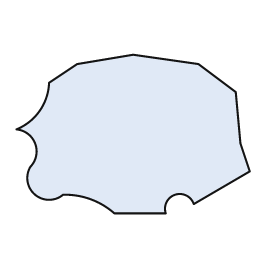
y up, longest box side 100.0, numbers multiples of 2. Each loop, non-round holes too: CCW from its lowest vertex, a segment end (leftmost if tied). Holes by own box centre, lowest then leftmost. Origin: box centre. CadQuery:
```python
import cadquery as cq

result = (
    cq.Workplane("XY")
    .moveTo(-8.0, -34.0)
    .lineTo(14.0, -34.0)
    .threePointArc((18.0, -26.0), (26.0, -30.0))
    .lineTo(50.0, -16.0)
    .lineTo(46.0, -4.0)
    .lineTo(44.0, 18.0)
    .lineTo(28.0, 30.0)
    .lineTo(0.0, 34.0)
    .lineTo(-24.0, 30.0)
    .lineTo(-36.0, 22.0)
    .threePointArc((-40.0, 10.0), (-50.0, 2.0))
    .threePointArc((-42.0, -4.0), (-44.0, -14.0))
    .threePointArc((-42.0, -26.0), (-30.0, -26.0))
    .threePointArc((-18.0, -28.0), (-8.0, -34.0))
    .close()
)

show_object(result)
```